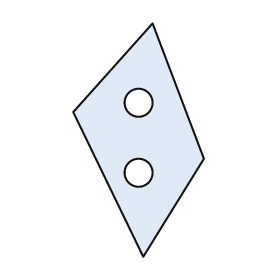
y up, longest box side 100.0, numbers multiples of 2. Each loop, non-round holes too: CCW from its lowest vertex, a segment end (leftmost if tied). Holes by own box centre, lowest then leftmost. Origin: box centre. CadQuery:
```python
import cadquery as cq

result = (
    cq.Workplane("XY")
    .moveTo(2.0, -50.0)
    .lineTo(28.0, -8.0)
    .lineTo(6.0, 50.0)
    .lineTo(-28.0, 12.0)
    .close()
    .moveTo(0.0, -14.0)
    .circle(6.0)
    .moveTo(0.0, 16.0)
    .circle(6.0)
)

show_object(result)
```